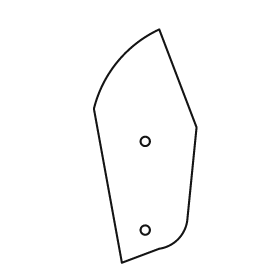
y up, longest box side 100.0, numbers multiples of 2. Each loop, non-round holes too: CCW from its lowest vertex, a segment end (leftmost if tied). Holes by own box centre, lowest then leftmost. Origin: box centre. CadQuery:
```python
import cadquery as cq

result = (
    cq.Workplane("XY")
    .moveTo(-10.0, -50.0)
    .lineTo(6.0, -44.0)
    .threePointArc((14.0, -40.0), (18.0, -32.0))
    .lineTo(22.0, 8.0)
    .lineTo(6.0, 50.0)
    .threePointArc((-12.0, 36.0), (-22.0, 16.0))
    .close()
    .moveTo(0.0, -36.0)
    .circle(2.0)
    .moveTo(0.0, 2.0)
    .circle(2.0)
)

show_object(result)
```